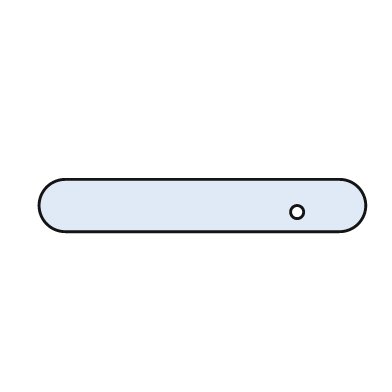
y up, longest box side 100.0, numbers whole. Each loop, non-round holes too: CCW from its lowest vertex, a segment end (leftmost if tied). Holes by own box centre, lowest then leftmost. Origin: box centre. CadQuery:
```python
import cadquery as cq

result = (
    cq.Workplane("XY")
    .moveTo(-42.0, -8.0)
    .lineTo(42.0, -8.0)
    .threePointArc((50.0, 0.0), (42.0, 8.0))
    .lineTo(-42.0, 8.0)
    .threePointArc((-50.0, 0.0), (-42.0, -8.0))
    .close()
    .moveTo(29.0, -2.0)
    .circle(2.0)
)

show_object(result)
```